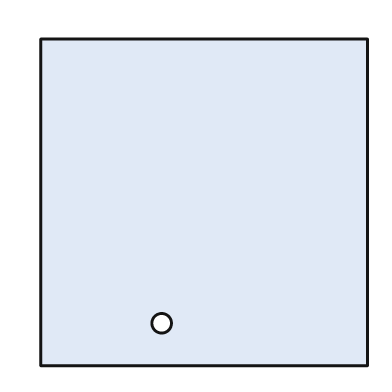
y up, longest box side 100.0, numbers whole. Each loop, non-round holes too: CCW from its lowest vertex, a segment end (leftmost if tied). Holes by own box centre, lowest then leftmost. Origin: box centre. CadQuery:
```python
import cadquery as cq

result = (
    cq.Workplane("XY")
    .moveTo(-50.0, -50.0)
    .lineTo(50.0, -50.0)
    .lineTo(50.0, 50.0)
    .lineTo(-50.0, 50.0)
    .close()
    .moveTo(-13.0, -37.0)
    .circle(3.0)
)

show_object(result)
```